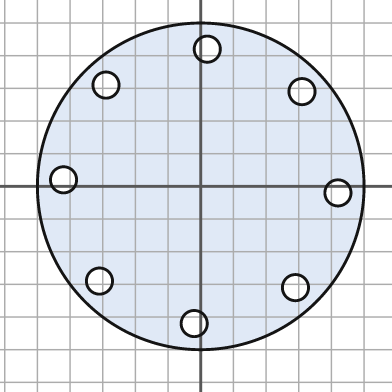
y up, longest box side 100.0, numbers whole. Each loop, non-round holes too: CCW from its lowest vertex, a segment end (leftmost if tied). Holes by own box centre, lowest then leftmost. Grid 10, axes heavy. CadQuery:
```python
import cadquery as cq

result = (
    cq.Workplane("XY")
    .moveTo(0.0, 0.0)
    .circle(50.0)
    .moveTo(-2.0, -42.0)
    .circle(4.0)
    .moveTo(29.0, -31.0)
    .circle(4.0)
    .moveTo(-31.0, -29.0)
    .circle(4.0)
    .moveTo(42.0, -2.0)
    .circle(4.0)
    .moveTo(-42.0, 2.0)
    .circle(4.0)
    .moveTo(31.0, 29.0)
    .circle(4.0)
    .moveTo(-29.0, 31.0)
    .circle(4.0)
    .moveTo(2.0, 42.0)
    .circle(4.0)
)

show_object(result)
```